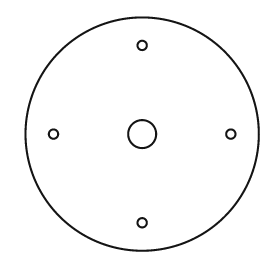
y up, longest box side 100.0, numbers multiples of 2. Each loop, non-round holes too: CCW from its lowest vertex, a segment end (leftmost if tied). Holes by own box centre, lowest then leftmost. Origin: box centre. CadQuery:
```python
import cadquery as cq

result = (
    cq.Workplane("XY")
    .moveTo(0.0, 0.0)
    .circle(50.0)
    .moveTo(0.0, -38.0)
    .circle(2.0)
    .moveTo(-38.0, 0.0)
    .circle(2.0)
    .moveTo(0.0, 0.0)
    .circle(6.0)
    .moveTo(38.0, 0.0)
    .circle(2.0)
    .moveTo(0.0, 38.0)
    .circle(2.0)
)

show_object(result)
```